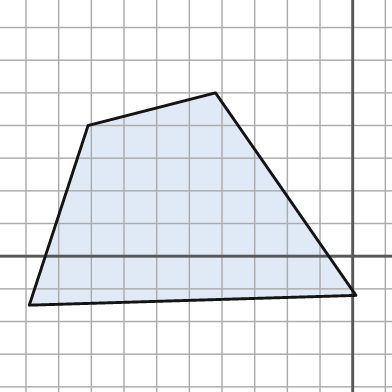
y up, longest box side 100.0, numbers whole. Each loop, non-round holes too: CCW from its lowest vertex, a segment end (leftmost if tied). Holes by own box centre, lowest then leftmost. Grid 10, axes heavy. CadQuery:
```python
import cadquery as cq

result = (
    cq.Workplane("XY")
    .moveTo(-99.0, -15.0)
    .lineTo(1.0, -12.0)
    .lineTo(-42.0, 50.0)
    .lineTo(-81.0, 40.0)
    .close()
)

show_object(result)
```